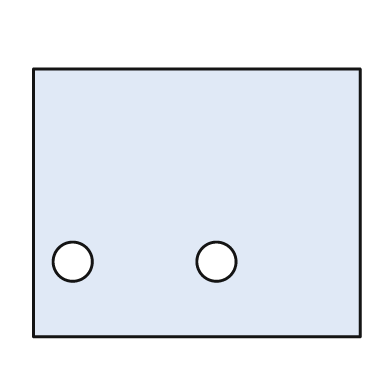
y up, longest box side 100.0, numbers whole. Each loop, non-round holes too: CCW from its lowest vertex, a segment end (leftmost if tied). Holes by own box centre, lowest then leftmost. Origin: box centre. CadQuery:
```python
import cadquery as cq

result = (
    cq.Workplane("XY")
    .moveTo(-50.0, -41.0)
    .lineTo(50.0, -41.0)
    .lineTo(50.0, 41.0)
    .lineTo(-50.0, 41.0)
    .close()
    .moveTo(-38.0, -18.0)
    .circle(6.0)
    .moveTo(6.0, -18.0)
    .circle(6.0)
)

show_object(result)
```